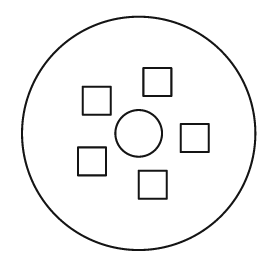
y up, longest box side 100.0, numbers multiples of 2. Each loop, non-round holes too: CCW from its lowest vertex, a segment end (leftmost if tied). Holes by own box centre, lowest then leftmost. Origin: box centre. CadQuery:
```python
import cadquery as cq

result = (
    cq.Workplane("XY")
    .moveTo(0.0, 0.0)
    .circle(50.0)
    .moveTo(0.0, -28.0)
    .lineTo(12.0, -28.0)
    .lineTo(12.0, -16.0)
    .lineTo(0.0, -16.0)
    .close()
    .moveTo(-26.0, -18.0)
    .lineTo(-14.0, -18.0)
    .lineTo(-14.0, -6.0)
    .lineTo(-26.0, -6.0)
    .close()
    .moveTo(18.0, -8.0)
    .lineTo(30.0, -8.0)
    .lineTo(30.0, 4.0)
    .lineTo(18.0, 4.0)
    .close()
    .moveTo(0.0, 0.0)
    .circle(10.0)
    .moveTo(-24.0, 8.0)
    .lineTo(-12.0, 8.0)
    .lineTo(-12.0, 20.0)
    .lineTo(-24.0, 20.0)
    .close()
    .moveTo(2.0, 16.0)
    .lineTo(14.0, 16.0)
    .lineTo(14.0, 28.0)
    .lineTo(2.0, 28.0)
    .close()
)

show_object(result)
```